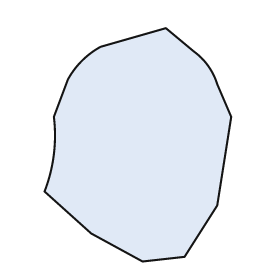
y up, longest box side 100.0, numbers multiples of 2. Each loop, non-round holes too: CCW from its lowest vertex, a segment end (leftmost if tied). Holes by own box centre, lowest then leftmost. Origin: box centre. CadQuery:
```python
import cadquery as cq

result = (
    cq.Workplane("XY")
    .moveTo(2.0, -50.0)
    .lineTo(20.0, -48.0)
    .lineTo(34.0, -26.0)
    .lineTo(40.0, 12.0)
    .lineTo(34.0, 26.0)
    .threePointArc((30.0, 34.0), (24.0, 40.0))
    .lineTo(12.0, 50.0)
    .lineTo(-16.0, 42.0)
    .threePointArc((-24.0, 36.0), (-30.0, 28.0))
    .lineTo(-36.0, 12.0)
    .threePointArc((-36.0, -4.0), (-40.0, -20.0))
    .lineTo(-20.0, -38.0)
    .close()
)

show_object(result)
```